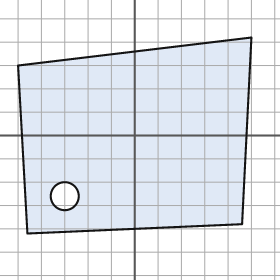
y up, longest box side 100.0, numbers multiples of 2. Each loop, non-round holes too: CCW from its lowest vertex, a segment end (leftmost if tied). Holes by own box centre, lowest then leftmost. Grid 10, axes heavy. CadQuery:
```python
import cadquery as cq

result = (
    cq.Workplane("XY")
    .moveTo(-46.0, -42.0)
    .lineTo(46.0, -38.0)
    .lineTo(50.0, 42.0)
    .lineTo(-50.0, 30.0)
    .close()
    .moveTo(-30.0, -26.0)
    .circle(6.0)
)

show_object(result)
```